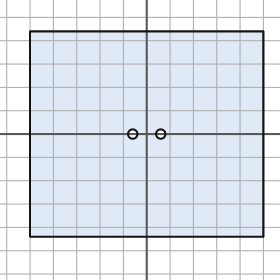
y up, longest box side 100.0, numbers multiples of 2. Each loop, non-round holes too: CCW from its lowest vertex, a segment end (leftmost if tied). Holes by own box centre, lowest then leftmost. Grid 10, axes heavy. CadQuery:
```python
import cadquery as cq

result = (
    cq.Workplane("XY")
    .moveTo(-50.0, -44.0)
    .lineTo(50.0, -44.0)
    .lineTo(50.0, 44.0)
    .lineTo(-50.0, 44.0)
    .close()
    .moveTo(-6.0, 0.0)
    .circle(2.0)
    .moveTo(6.0, 0.0)
    .circle(2.0)
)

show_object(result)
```